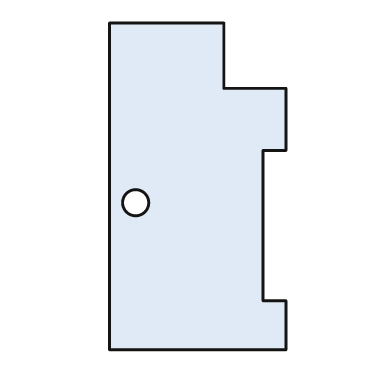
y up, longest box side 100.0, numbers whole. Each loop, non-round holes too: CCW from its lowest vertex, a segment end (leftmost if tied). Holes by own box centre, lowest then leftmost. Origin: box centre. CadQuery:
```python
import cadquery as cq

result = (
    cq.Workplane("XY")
    .moveTo(-27.0, -50.0)
    .lineTo(27.0, -50.0)
    .lineTo(27.0, -35.0)
    .lineTo(20.0, -35.0)
    .lineTo(20.0, 11.0)
    .lineTo(27.0, 11.0)
    .lineTo(27.0, 30.0)
    .lineTo(8.0, 30.0)
    .lineTo(8.0, 50.0)
    .lineTo(-27.0, 50.0)
    .close()
    .moveTo(-19.0, -5.0)
    .circle(4.0)
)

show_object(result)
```